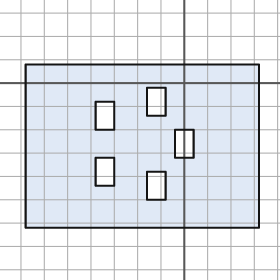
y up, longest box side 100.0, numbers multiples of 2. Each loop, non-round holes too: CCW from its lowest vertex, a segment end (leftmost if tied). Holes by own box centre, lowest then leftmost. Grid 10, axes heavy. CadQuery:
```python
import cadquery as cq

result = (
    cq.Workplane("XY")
    .moveTo(-68.0, -62.0)
    .lineTo(32.0, -62.0)
    .lineTo(32.0, 8.0)
    .lineTo(-68.0, 8.0)
    .close()
    .moveTo(-16.0, -50.0)
    .lineTo(-8.0, -50.0)
    .lineTo(-8.0, -38.0)
    .lineTo(-16.0, -38.0)
    .close()
    .moveTo(-38.0, -44.0)
    .lineTo(-30.0, -44.0)
    .lineTo(-30.0, -32.0)
    .lineTo(-38.0, -32.0)
    .close()
    .moveTo(-4.0, -32.0)
    .lineTo(4.0, -32.0)
    .lineTo(4.0, -20.0)
    .lineTo(-4.0, -20.0)
    .close()
    .moveTo(-38.0, -20.0)
    .lineTo(-30.0, -20.0)
    .lineTo(-30.0, -8.0)
    .lineTo(-38.0, -8.0)
    .close()
    .moveTo(-16.0, -14.0)
    .lineTo(-8.0, -14.0)
    .lineTo(-8.0, -2.0)
    .lineTo(-16.0, -2.0)
    .close()
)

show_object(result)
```